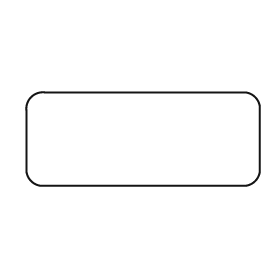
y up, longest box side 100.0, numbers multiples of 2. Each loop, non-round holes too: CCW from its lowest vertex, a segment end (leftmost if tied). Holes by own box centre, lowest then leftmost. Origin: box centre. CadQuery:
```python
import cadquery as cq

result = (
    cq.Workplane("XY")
    .moveTo(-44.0, -20.0)
    .lineTo(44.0, -20.0)
    .threePointArc((48.0, -18.0), (50.0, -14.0))
    .lineTo(50.0, 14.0)
    .threePointArc((48.0, 18.0), (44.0, 20.0))
    .lineTo(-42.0, 20.0)
    .threePointArc((-48.0, 18.0), (-50.0, 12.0))
    .lineTo(-50.0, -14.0)
    .threePointArc((-48.0, -18.0), (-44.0, -20.0))
    .close()
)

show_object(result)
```